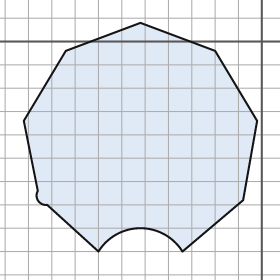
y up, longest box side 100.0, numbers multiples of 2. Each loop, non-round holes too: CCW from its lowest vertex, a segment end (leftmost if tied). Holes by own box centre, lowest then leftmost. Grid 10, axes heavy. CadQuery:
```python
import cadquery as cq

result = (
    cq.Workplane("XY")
    .moveTo(-70.0, -90.0)
    .threePointArc((-52.0, -80.0), (-34.0, -90.0))
    .lineTo(-8.0, -68.0)
    .lineTo(-2.0, -34.0)
    .lineTo(-20.0, -4.0)
    .lineTo(-52.0, 8.0)
    .lineTo(-84.0, -4.0)
    .lineTo(-102.0, -34.0)
    .lineTo(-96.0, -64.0)
    .threePointArc((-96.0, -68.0), (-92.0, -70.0))
    .close()
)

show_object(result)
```